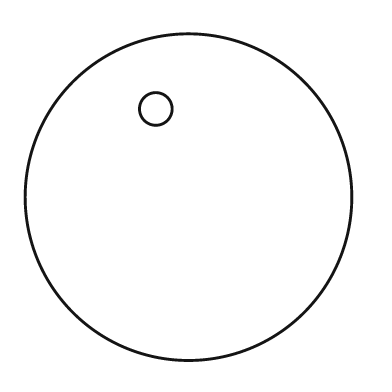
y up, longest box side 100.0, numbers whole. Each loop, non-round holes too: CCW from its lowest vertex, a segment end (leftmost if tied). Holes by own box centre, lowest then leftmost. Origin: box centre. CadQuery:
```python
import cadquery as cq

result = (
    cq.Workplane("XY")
    .moveTo(0.0, 0.0)
    .circle(50.0)
    .moveTo(-10.0, 27.0)
    .circle(5.0)
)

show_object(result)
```